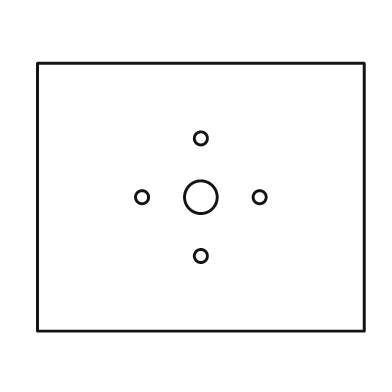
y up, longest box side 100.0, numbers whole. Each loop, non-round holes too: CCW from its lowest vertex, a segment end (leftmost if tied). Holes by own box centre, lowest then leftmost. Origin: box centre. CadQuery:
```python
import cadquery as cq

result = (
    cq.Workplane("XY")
    .moveTo(-50.0, -41.0)
    .lineTo(50.0, -41.0)
    .lineTo(50.0, 41.0)
    .lineTo(-50.0, 41.0)
    .close()
    .moveTo(0.0, -18.0)
    .circle(2.0)
    .moveTo(-18.0, 0.0)
    .circle(2.0)
    .moveTo(0.0, 0.0)
    .circle(5.0)
    .moveTo(18.0, 0.0)
    .circle(2.0)
    .moveTo(0.0, 18.0)
    .circle(2.0)
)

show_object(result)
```